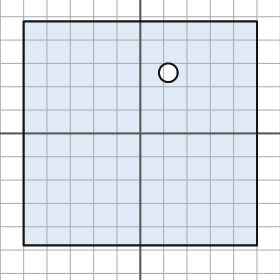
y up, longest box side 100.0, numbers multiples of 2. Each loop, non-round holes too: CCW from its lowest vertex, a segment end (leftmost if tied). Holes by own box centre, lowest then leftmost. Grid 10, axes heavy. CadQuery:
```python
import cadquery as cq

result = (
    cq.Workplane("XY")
    .moveTo(-50.0, -48.0)
    .lineTo(50.0, -48.0)
    .lineTo(50.0, 48.0)
    .lineTo(-50.0, 48.0)
    .close()
    .moveTo(12.0, 26.0)
    .circle(4.0)
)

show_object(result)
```